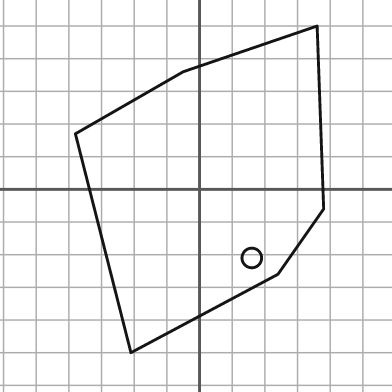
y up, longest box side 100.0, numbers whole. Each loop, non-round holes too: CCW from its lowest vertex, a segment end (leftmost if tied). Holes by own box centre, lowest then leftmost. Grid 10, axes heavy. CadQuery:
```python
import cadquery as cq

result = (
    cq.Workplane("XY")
    .moveTo(-21.0, -50.0)
    .lineTo(24.0, -26.0)
    .lineTo(38.0, -6.0)
    .lineTo(36.0, 50.0)
    .lineTo(-5.0, 36.0)
    .lineTo(-38.0, 17.0)
    .close()
    .moveTo(16.0, -21.0)
    .circle(3.0)
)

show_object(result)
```